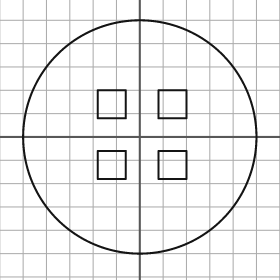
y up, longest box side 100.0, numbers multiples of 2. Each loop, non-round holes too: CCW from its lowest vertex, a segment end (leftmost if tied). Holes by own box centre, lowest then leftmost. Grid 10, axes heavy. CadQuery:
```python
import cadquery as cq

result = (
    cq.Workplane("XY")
    .moveTo(0.0, 0.0)
    .circle(50.0)
    .moveTo(-18.0, -18.0)
    .lineTo(-6.0, -18.0)
    .lineTo(-6.0, -6.0)
    .lineTo(-18.0, -6.0)
    .close()
    .moveTo(8.0, -18.0)
    .lineTo(20.0, -18.0)
    .lineTo(20.0, -6.0)
    .lineTo(8.0, -6.0)
    .close()
    .moveTo(-18.0, 8.0)
    .lineTo(-6.0, 8.0)
    .lineTo(-6.0, 20.0)
    .lineTo(-18.0, 20.0)
    .close()
    .moveTo(8.0, 8.0)
    .lineTo(20.0, 8.0)
    .lineTo(20.0, 20.0)
    .lineTo(8.0, 20.0)
    .close()
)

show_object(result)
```